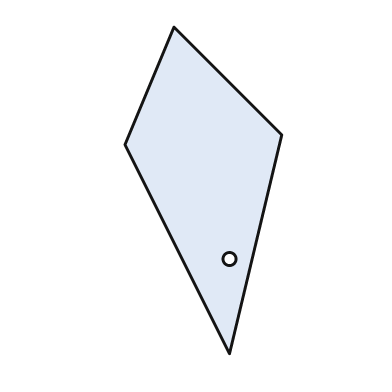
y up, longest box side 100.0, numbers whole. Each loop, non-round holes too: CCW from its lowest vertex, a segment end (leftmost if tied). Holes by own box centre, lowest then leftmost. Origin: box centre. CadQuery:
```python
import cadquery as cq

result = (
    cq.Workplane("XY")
    .moveTo(8.0, -50.0)
    .lineTo(24.0, 17.0)
    .lineTo(-9.0, 50.0)
    .lineTo(-24.0, 14.0)
    .close()
    .moveTo(8.0, -21.0)
    .circle(2.0)
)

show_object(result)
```